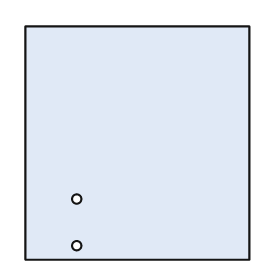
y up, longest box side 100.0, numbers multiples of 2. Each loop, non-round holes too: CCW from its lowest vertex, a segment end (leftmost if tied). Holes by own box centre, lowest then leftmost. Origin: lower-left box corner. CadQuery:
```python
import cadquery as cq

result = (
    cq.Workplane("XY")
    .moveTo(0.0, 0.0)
    .lineTo(96.0, 0.0)
    .lineTo(96.0, 100.0)
    .lineTo(0.0, 100.0)
    .close()
    .moveTo(22.0, 6.0)
    .circle(2.0)
    .moveTo(22.0, 26.0)
    .circle(2.0)
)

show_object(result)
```